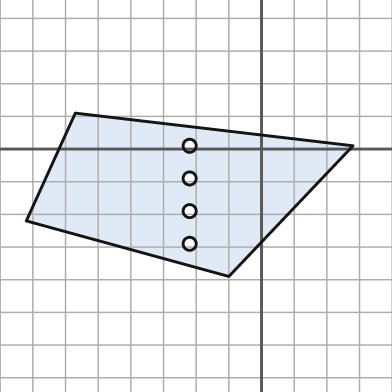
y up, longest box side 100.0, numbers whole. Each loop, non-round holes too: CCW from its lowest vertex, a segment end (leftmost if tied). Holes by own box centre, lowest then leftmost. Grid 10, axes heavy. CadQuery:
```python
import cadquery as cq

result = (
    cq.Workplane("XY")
    .moveTo(-10.0, -39.0)
    .lineTo(28.0, 1.0)
    .lineTo(-57.0, 11.0)
    .lineTo(-72.0, -22.0)
    .close()
    .moveTo(-22.0, -29.0)
    .circle(2.0)
    .moveTo(-22.0, -19.0)
    .circle(2.0)
    .moveTo(-22.0, -9.0)
    .circle(2.0)
    .moveTo(-22.0, 1.0)
    .circle(2.0)
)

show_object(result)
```